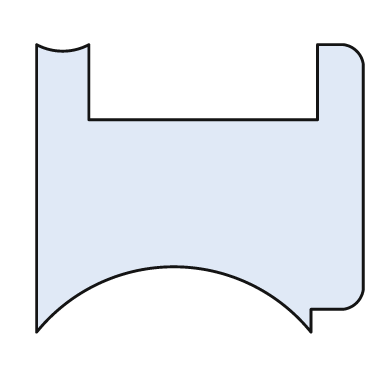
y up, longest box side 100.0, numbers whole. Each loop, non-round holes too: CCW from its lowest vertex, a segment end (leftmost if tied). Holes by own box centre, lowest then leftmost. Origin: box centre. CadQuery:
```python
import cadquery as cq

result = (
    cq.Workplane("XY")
    .moveTo(-50.0, -44.0)
    .threePointArc((-8.0, -24.0), (34.0, -44.0))
    .lineTo(34.0, -37.0)
    .lineTo(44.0, -37.0)
    .threePointArc((48.0, -35.0), (50.0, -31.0))
    .lineTo(50.0, 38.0)
    .threePointArc((48.0, 42.0), (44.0, 44.0))
    .lineTo(36.0, 44.0)
    .lineTo(36.0, 21.0)
    .lineTo(-34.0, 21.0)
    .lineTo(-34.0, 44.0)
    .threePointArc((-42.0, 42.0), (-50.0, 44.0))
    .close()
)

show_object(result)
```